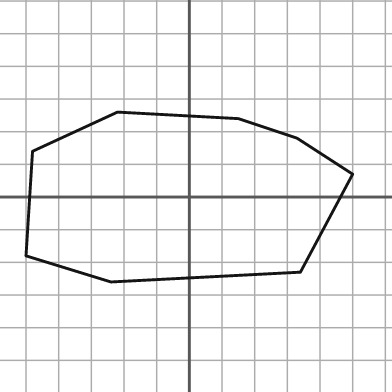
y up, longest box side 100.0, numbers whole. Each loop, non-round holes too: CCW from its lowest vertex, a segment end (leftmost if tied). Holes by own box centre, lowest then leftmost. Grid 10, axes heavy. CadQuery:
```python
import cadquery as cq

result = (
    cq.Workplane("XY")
    .moveTo(-24.0, -26.0)
    .lineTo(34.0, -23.0)
    .lineTo(50.0, 7.0)
    .lineTo(33.0, 18.0)
    .lineTo(15.0, 24.0)
    .lineTo(-22.0, 26.0)
    .lineTo(-48.0, 14.0)
    .lineTo(-50.0, -18.0)
    .close()
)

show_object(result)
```